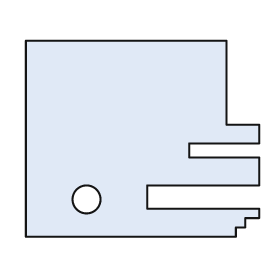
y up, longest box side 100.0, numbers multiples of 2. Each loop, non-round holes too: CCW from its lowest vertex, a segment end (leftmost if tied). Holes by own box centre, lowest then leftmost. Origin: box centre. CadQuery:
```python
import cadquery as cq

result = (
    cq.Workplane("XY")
    .moveTo(-50.0, -42.0)
    .lineTo(40.0, -42.0)
    .lineTo(40.0, -38.0)
    .lineTo(44.0, -38.0)
    .lineTo(44.0, -34.0)
    .lineTo(50.0, -34.0)
    .lineTo(50.0, -30.0)
    .lineTo(2.0, -30.0)
    .lineTo(2.0, -20.0)
    .lineTo(50.0, -20.0)
    .lineTo(50.0, -8.0)
    .lineTo(20.0, -8.0)
    .lineTo(20.0, -2.0)
    .lineTo(50.0, -2.0)
    .lineTo(50.0, 6.0)
    .lineTo(36.0, 6.0)
    .lineTo(36.0, 42.0)
    .lineTo(-50.0, 42.0)
    .close()
    .moveTo(-24.0, -26.0)
    .circle(6.0)
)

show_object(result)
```